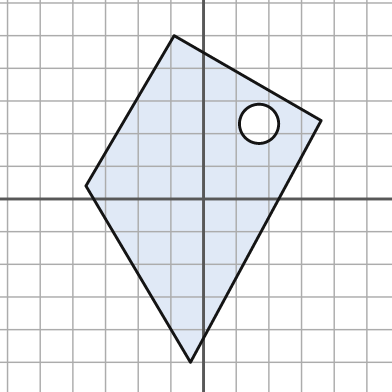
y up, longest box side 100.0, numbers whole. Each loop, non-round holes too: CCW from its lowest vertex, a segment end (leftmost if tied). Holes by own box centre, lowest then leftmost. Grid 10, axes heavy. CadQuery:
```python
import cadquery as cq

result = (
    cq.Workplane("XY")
    .moveTo(-4.0, -50.0)
    .lineTo(36.0, 24.0)
    .lineTo(-9.0, 50.0)
    .lineTo(-36.0, 4.0)
    .close()
    .moveTo(17.0, 23.0)
    .circle(6.0)
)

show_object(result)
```